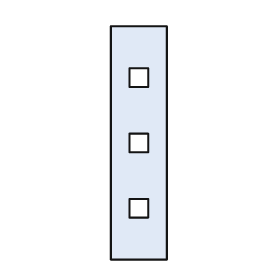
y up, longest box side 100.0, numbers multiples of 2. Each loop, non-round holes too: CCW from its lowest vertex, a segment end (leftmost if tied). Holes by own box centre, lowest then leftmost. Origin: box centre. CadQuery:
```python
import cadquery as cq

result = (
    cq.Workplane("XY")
    .moveTo(-12.0, -50.0)
    .lineTo(12.0, -50.0)
    .lineTo(12.0, 50.0)
    .lineTo(-12.0, 50.0)
    .close()
    .moveTo(-4.0, -32.0)
    .lineTo(4.0, -32.0)
    .lineTo(4.0, -24.0)
    .lineTo(-4.0, -24.0)
    .close()
    .moveTo(-4.0, -4.0)
    .lineTo(4.0, -4.0)
    .lineTo(4.0, 4.0)
    .lineTo(-4.0, 4.0)
    .close()
    .moveTo(-4.0, 24.0)
    .lineTo(4.0, 24.0)
    .lineTo(4.0, 32.0)
    .lineTo(-4.0, 32.0)
    .close()
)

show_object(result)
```